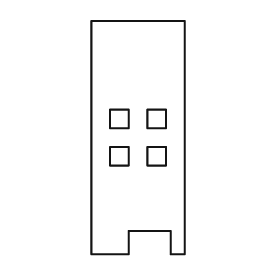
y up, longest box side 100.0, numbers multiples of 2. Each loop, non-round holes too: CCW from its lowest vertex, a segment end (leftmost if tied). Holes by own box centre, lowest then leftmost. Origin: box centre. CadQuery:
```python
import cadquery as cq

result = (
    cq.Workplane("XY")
    .moveTo(-20.0, -50.0)
    .lineTo(-4.0, -50.0)
    .lineTo(-4.0, -40.0)
    .lineTo(14.0, -40.0)
    .lineTo(14.0, -50.0)
    .lineTo(20.0, -50.0)
    .lineTo(20.0, 50.0)
    .lineTo(-20.0, 50.0)
    .close()
    .moveTo(-12.0, -12.0)
    .lineTo(-4.0, -12.0)
    .lineTo(-4.0, -4.0)
    .lineTo(-12.0, -4.0)
    .close()
    .moveTo(4.0, -12.0)
    .lineTo(12.0, -12.0)
    .lineTo(12.0, -4.0)
    .lineTo(4.0, -4.0)
    .close()
    .moveTo(-12.0, 4.0)
    .lineTo(-4.0, 4.0)
    .lineTo(-4.0, 12.0)
    .lineTo(-12.0, 12.0)
    .close()
    .moveTo(4.0, 4.0)
    .lineTo(12.0, 4.0)
    .lineTo(12.0, 12.0)
    .lineTo(4.0, 12.0)
    .close()
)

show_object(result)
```